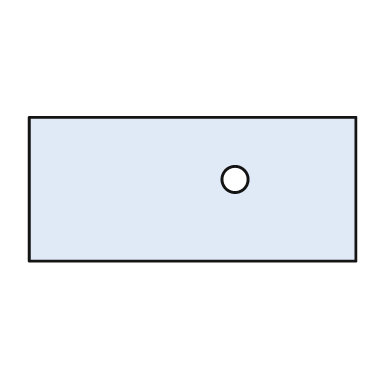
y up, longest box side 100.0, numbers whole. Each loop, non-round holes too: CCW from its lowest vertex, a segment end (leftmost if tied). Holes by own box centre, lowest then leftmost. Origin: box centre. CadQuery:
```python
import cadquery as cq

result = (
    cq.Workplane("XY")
    .moveTo(-50.0, -22.0)
    .lineTo(50.0, -22.0)
    .lineTo(50.0, 22.0)
    .lineTo(-50.0, 22.0)
    .close()
    .moveTo(13.0, 3.0)
    .circle(4.0)
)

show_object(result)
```